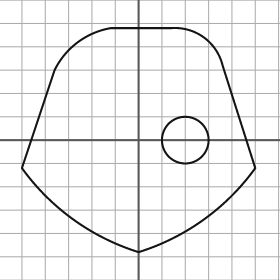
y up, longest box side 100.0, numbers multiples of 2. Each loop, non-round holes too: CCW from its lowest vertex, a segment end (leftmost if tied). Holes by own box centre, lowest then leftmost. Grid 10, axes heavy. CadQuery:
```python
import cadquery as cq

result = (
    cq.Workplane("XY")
    .moveTo(0.0, -48.0)
    .threePointArc((28.0, -34.0), (50.0, -12.0))
    .lineTo(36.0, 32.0)
    .threePointArc((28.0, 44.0), (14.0, 48.0))
    .lineTo(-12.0, 48.0)
    .threePointArc((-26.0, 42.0), (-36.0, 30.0))
    .lineTo(-50.0, -12.0)
    .threePointArc((-28.0, -34.0), (0.0, -48.0))
    .close()
    .moveTo(20.0, 0.0)
    .circle(10.0)
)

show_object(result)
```